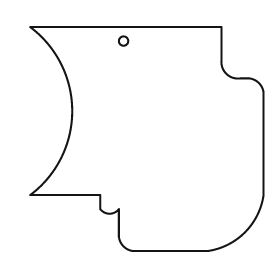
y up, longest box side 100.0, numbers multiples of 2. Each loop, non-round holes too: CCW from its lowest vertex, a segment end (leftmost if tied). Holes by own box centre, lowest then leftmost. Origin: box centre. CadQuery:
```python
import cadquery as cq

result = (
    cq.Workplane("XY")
    .moveTo(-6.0, -48.0)
    .lineTo(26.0, -48.0)
    .threePointArc((42.0, -40.0), (50.0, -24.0))
    .lineTo(50.0, 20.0)
    .threePointArc((48.0, 24.0), (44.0, 26.0))
    .lineTo(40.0, 26.0)
    .threePointArc((34.0, 28.0), (32.0, 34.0))
    .lineTo(32.0, 48.0)
    .lineTo(-50.0, 48.0)
    .threePointArc((-32.0, 12.0), (-50.0, -24.0))
    .lineTo(-20.0, -24.0)
    .lineTo(-20.0, -30.0)
    .threePointArc((-16.0, -32.0), (-12.0, -30.0))
    .lineTo(-12.0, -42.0)
    .threePointArc((-10.0, -46.0), (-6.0, -48.0))
    .close()
    .moveTo(-10.0, 42.0)
    .circle(2.0)
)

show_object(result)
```